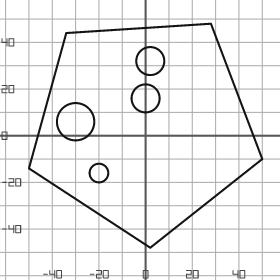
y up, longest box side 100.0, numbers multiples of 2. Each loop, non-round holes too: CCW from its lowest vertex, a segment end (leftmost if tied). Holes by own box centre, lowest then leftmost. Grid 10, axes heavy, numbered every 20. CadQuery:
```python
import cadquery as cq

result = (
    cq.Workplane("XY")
    .moveTo(2.0, -48.0)
    .lineTo(50.0, -10.0)
    .lineTo(28.0, 48.0)
    .lineTo(-34.0, 44.0)
    .lineTo(-50.0, -14.0)
    .close()
    .moveTo(-20.0, -16.0)
    .circle(4.0)
    .moveTo(-30.0, 6.0)
    .circle(8.0)
    .moveTo(0.0, 16.0)
    .circle(6.0)
    .moveTo(2.0, 32.0)
    .circle(6.0)
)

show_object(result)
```